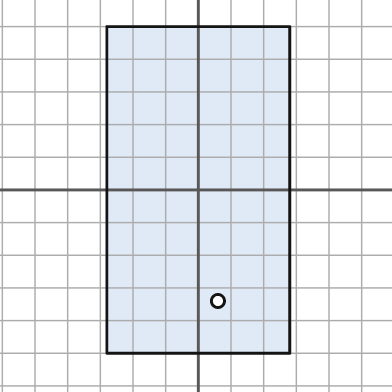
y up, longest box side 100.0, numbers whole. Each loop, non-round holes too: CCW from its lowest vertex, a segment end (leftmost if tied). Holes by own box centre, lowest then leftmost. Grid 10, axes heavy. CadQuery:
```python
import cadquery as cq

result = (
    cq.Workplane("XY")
    .moveTo(-28.0, -50.0)
    .lineTo(28.0, -50.0)
    .lineTo(28.0, 50.0)
    .lineTo(-28.0, 50.0)
    .close()
    .moveTo(6.0, -34.0)
    .circle(2.0)
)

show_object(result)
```